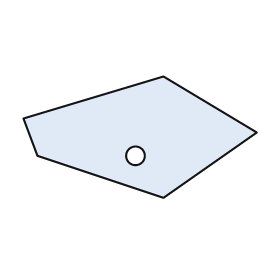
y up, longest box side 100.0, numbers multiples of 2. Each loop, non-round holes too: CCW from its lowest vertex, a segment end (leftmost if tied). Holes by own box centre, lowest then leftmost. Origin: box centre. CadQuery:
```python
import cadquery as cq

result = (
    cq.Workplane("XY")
    .moveTo(10.0, -26.0)
    .lineTo(50.0, 2.0)
    .lineTo(10.0, 26.0)
    .lineTo(-50.0, 8.0)
    .lineTo(-44.0, -8.0)
    .close()
    .moveTo(-2.0, -8.0)
    .circle(4.0)
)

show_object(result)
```